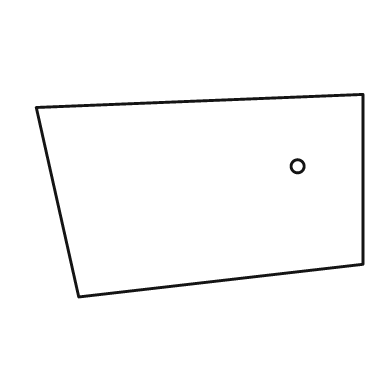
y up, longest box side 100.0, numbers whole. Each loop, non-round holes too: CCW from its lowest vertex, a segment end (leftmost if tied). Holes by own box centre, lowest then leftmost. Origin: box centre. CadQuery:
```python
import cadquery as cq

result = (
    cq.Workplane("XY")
    .moveTo(-37.0, -31.0)
    .lineTo(50.0, -21.0)
    .lineTo(50.0, 31.0)
    .lineTo(-50.0, 27.0)
    .close()
    .moveTo(30.0, 9.0)
    .circle(2.0)
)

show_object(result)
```